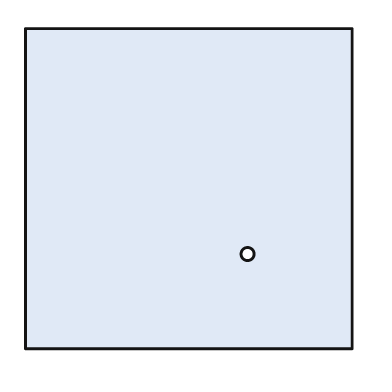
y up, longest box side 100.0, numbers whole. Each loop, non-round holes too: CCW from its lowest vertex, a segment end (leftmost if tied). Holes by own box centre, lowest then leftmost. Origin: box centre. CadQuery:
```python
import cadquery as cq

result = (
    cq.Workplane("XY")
    .moveTo(-50.0, -49.0)
    .lineTo(50.0, -49.0)
    .lineTo(50.0, 49.0)
    .lineTo(-50.0, 49.0)
    .close()
    .moveTo(18.0, -20.0)
    .circle(2.0)
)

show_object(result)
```